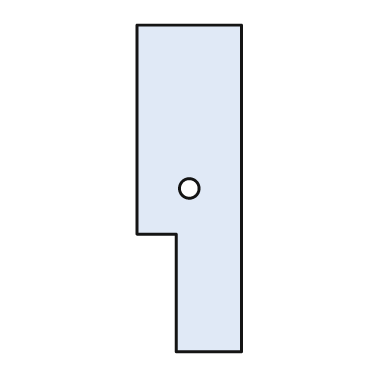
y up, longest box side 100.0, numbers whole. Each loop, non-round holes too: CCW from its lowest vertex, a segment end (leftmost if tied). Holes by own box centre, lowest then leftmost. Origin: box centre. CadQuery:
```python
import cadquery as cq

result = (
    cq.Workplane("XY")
    .moveTo(-4.0, -50.0)
    .lineTo(16.0, -50.0)
    .lineTo(16.0, 50.0)
    .lineTo(-16.0, 50.0)
    .lineTo(-16.0, -14.0)
    .lineTo(-4.0, -14.0)
    .close()
    .moveTo(0.0, 0.0)
    .circle(3.0)
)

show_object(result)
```